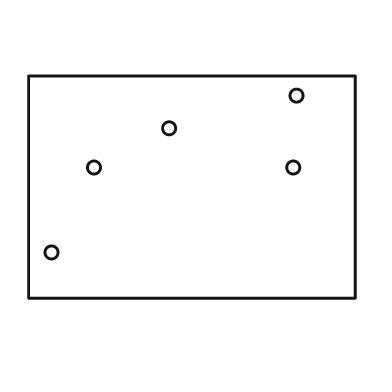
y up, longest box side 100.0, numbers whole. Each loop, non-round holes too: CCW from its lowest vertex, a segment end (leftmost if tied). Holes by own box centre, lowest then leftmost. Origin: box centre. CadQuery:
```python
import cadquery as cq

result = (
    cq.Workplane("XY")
    .moveTo(-50.0, -34.0)
    .lineTo(50.0, -34.0)
    .lineTo(50.0, 34.0)
    .lineTo(-50.0, 34.0)
    .close()
    .moveTo(-43.0, -20.0)
    .circle(2.0)
    .moveTo(-30.0, 6.0)
    .circle(2.0)
    .moveTo(31.0, 6.0)
    .circle(2.0)
    .moveTo(-7.0, 18.0)
    .circle(2.0)
    .moveTo(32.0, 28.0)
    .circle(2.0)
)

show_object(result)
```